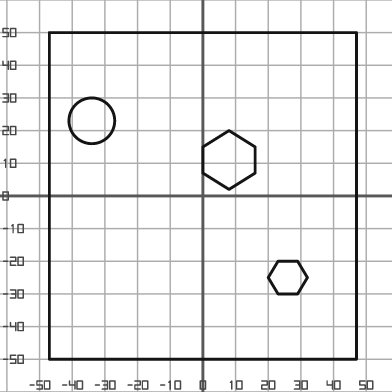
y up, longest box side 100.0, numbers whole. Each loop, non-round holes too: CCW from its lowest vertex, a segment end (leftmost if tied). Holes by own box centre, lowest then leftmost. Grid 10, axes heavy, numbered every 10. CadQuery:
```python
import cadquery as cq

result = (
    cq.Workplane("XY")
    .moveTo(-47.0, -50.0)
    .lineTo(47.0, -50.0)
    .lineTo(47.0, 50.0)
    .lineTo(-47.0, 50.0)
    .close()
    .moveTo(23.0, -30.0)
    .lineTo(29.0, -30.0)
    .lineTo(32.0, -25.0)
    .lineTo(29.0, -20.0)
    .lineTo(23.0, -20.0)
    .lineTo(20.0, -25.0)
    .close()
    .moveTo(8.0, 2.0)
    .lineTo(16.0, 7.0)
    .lineTo(16.0, 15.0)
    .lineTo(8.0, 20.0)
    .lineTo(0.0, 15.0)
    .lineTo(0.0, 7.0)
    .close()
    .moveTo(-34.0, 23.0)
    .circle(7.0)
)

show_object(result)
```